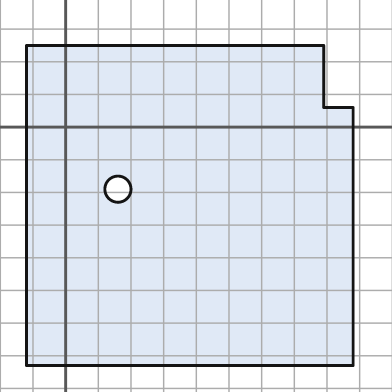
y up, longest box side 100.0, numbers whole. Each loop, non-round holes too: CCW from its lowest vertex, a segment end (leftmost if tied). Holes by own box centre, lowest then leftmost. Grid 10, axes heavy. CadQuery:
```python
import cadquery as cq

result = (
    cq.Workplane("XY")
    .moveTo(-12.0, -73.0)
    .lineTo(88.0, -73.0)
    .lineTo(88.0, 6.0)
    .lineTo(79.0, 6.0)
    .lineTo(79.0, 25.0)
    .lineTo(-12.0, 25.0)
    .close()
    .moveTo(16.0, -19.0)
    .circle(4.0)
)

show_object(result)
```